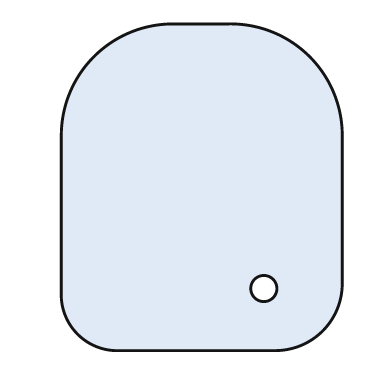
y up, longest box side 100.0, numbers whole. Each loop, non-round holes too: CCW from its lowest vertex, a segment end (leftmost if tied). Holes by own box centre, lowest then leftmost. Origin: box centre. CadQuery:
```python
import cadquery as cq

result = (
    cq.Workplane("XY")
    .moveTo(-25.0, -50.0)
    .lineTo(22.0, -50.0)
    .threePointArc((37.0, -44.0), (43.0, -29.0))
    .lineTo(43.0, 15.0)
    .threePointArc((33.0, 40.0), (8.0, 50.0))
    .lineTo(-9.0, 50.0)
    .threePointArc((-33.0, 40.0), (-43.0, 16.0))
    .lineTo(-43.0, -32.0)
    .threePointArc((-38.0, -45.0), (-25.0, -50.0))
    .close()
    .moveTo(19.0, -31.0)
    .circle(4.0)
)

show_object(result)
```